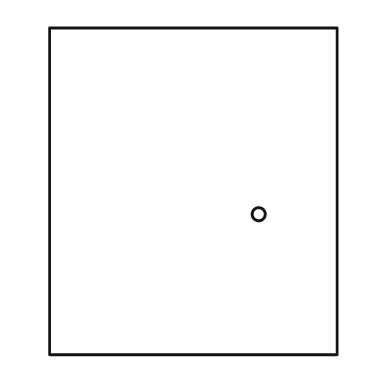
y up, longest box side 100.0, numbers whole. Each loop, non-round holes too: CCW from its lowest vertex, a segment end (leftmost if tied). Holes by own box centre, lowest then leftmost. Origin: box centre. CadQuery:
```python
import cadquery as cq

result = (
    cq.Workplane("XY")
    .moveTo(-44.0, -50.0)
    .lineTo(44.0, -50.0)
    .lineTo(44.0, 50.0)
    .lineTo(-44.0, 50.0)
    .close()
    .moveTo(20.0, -7.0)
    .circle(2.0)
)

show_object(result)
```